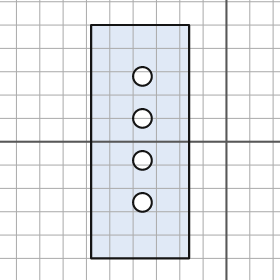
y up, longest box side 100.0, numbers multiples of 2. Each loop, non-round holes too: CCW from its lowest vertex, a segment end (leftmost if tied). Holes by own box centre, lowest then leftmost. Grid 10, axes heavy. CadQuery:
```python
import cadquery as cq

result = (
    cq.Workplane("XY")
    .moveTo(-58.0, -50.0)
    .lineTo(-16.0, -50.0)
    .lineTo(-16.0, 50.0)
    .lineTo(-58.0, 50.0)
    .close()
    .moveTo(-36.0, -26.0)
    .circle(4.0)
    .moveTo(-36.0, -8.0)
    .circle(4.0)
    .moveTo(-36.0, 10.0)
    .circle(4.0)
    .moveTo(-36.0, 28.0)
    .circle(4.0)
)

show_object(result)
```